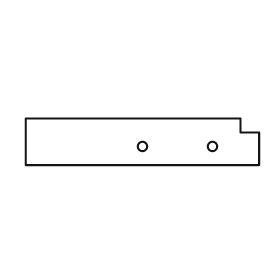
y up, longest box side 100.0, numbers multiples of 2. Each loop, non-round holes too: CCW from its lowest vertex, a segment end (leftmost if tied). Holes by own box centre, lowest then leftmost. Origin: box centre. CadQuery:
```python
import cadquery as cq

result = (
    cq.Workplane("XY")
    .moveTo(-50.0, -10.0)
    .lineTo(50.0, -10.0)
    .lineTo(50.0, 4.0)
    .lineTo(42.0, 4.0)
    .lineTo(42.0, 10.0)
    .lineTo(-50.0, 10.0)
    .close()
    .moveTo(0.0, -2.0)
    .circle(2.0)
    .moveTo(30.0, -2.0)
    .circle(2.0)
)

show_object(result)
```